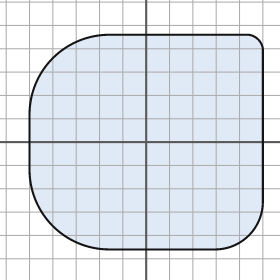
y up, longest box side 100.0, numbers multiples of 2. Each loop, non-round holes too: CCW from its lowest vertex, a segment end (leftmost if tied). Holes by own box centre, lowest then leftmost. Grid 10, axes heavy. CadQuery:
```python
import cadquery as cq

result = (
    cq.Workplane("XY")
    .moveTo(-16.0, -46.0)
    .lineTo(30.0, -46.0)
    .threePointArc((44.0, -40.0), (50.0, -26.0))
    .lineTo(50.0, 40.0)
    .threePointArc((48.0, 44.0), (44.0, 46.0))
    .lineTo(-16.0, 46.0)
    .threePointArc((-40.0, 36.0), (-50.0, 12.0))
    .lineTo(-50.0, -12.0)
    .threePointArc((-40.0, -36.0), (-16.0, -46.0))
    .close()
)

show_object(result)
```